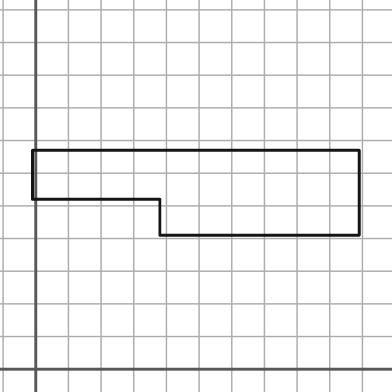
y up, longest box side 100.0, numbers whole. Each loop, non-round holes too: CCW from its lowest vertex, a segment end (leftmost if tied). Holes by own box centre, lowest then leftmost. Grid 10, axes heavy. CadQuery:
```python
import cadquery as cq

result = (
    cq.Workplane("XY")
    .moveTo(38.0, 41.0)
    .lineTo(99.0, 41.0)
    .lineTo(99.0, 67.0)
    .lineTo(-1.0, 67.0)
    .lineTo(-1.0, 52.0)
    .lineTo(38.0, 52.0)
    .close()
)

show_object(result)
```